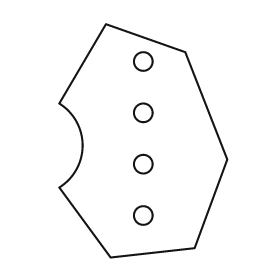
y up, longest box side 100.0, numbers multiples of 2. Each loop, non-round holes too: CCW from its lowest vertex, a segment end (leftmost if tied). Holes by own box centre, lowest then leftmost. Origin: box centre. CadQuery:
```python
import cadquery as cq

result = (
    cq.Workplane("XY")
    .moveTo(-14.0, -50.0)
    .lineTo(22.0, -46.0)
    .lineTo(36.0, -8.0)
    .lineTo(18.0, 38.0)
    .lineTo(-16.0, 50.0)
    .lineTo(-36.0, 16.0)
    .threePointArc((-26.0, -2.0), (-36.0, -20.0))
    .close()
    .moveTo(0.0, -32.0)
    .circle(4.0)
    .moveTo(0.0, -10.0)
    .circle(4.0)
    .moveTo(0.0, 12.0)
    .circle(4.0)
    .moveTo(0.0, 34.0)
    .circle(4.0)
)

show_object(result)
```